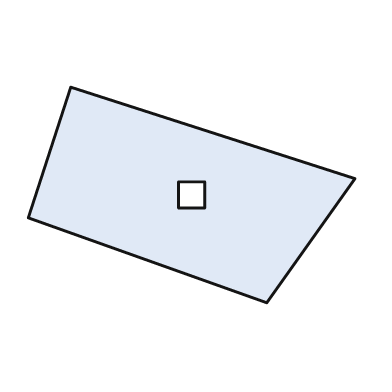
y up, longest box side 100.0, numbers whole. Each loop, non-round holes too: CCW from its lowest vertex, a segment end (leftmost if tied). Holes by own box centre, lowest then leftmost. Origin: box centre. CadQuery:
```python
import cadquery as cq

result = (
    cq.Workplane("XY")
    .moveTo(23.0, -33.0)
    .lineTo(50.0, 5.0)
    .lineTo(-37.0, 33.0)
    .lineTo(-50.0, -7.0)
    .close()
    .moveTo(-4.0, -4.0)
    .lineTo(4.0, -4.0)
    .lineTo(4.0, 4.0)
    .lineTo(-4.0, 4.0)
    .close()
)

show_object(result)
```